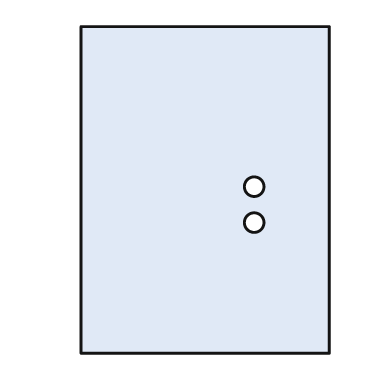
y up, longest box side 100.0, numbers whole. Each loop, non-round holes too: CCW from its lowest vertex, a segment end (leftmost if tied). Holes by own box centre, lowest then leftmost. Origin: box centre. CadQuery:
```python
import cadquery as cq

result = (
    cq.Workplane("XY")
    .moveTo(-38.0, -50.0)
    .lineTo(38.0, -50.0)
    .lineTo(38.0, 50.0)
    .lineTo(-38.0, 50.0)
    .close()
    .moveTo(15.0, -10.0)
    .circle(3.0)
    .moveTo(15.0, 1.0)
    .circle(3.0)
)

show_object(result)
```